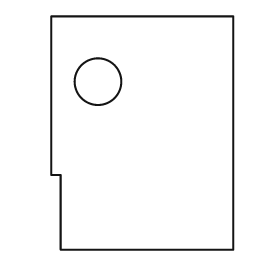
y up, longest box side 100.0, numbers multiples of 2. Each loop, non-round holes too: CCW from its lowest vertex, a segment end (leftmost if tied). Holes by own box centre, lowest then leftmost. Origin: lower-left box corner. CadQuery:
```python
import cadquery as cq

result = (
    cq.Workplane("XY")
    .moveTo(4.0, 0.0)
    .lineTo(78.0, 0.0)
    .lineTo(78.0, 100.0)
    .lineTo(0.0, 100.0)
    .lineTo(0.0, 32.0)
    .lineTo(4.0, 32.0)
    .close()
    .moveTo(20.0, 72.0)
    .circle(10.0)
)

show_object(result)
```